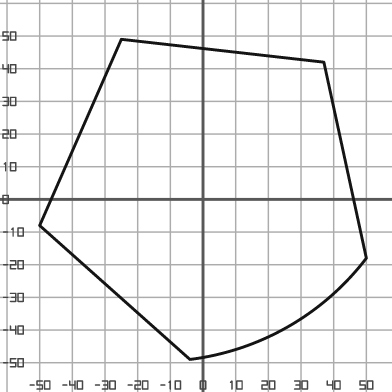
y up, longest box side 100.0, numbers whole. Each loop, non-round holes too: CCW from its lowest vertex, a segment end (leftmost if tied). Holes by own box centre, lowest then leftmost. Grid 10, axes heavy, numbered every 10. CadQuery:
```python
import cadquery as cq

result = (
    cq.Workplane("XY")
    .moveTo(-4.0, -49.0)
    .threePointArc((26.0, -39.0), (50.0, -18.0))
    .lineTo(37.0, 42.0)
    .lineTo(-25.0, 49.0)
    .lineTo(-50.0, -8.0)
    .close()
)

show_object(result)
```